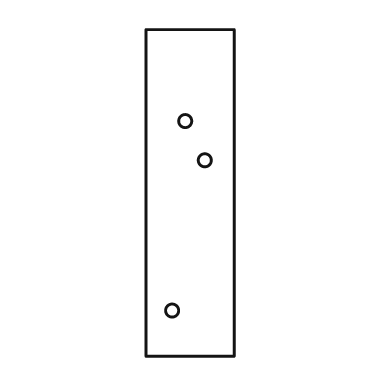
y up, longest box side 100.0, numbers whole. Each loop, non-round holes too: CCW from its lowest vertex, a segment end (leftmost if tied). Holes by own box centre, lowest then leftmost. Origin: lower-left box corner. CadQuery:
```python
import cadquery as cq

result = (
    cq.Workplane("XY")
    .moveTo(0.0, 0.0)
    .lineTo(27.0, 0.0)
    .lineTo(27.0, 100.0)
    .lineTo(0.0, 100.0)
    .close()
    .moveTo(8.0, 14.0)
    .circle(2.0)
    .moveTo(18.0, 60.0)
    .circle(2.0)
    .moveTo(12.0, 72.0)
    .circle(2.0)
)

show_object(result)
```